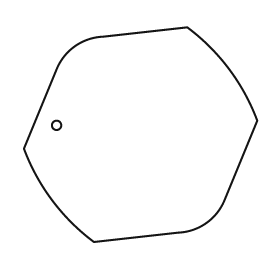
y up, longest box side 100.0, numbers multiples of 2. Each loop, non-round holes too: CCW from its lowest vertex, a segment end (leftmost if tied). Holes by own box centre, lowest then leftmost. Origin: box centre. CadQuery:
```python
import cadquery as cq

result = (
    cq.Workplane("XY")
    .moveTo(-20.0, -46.0)
    .lineTo(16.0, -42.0)
    .threePointArc((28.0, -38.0), (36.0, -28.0))
    .lineTo(50.0, 6.0)
    .threePointArc((38.0, 28.0), (20.0, 46.0))
    .lineTo(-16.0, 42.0)
    .threePointArc((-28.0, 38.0), (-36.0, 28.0))
    .lineTo(-50.0, -6.0)
    .threePointArc((-38.0, -28.0), (-20.0, -46.0))
    .close()
    .moveTo(-36.0, 4.0)
    .circle(2.0)
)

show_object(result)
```